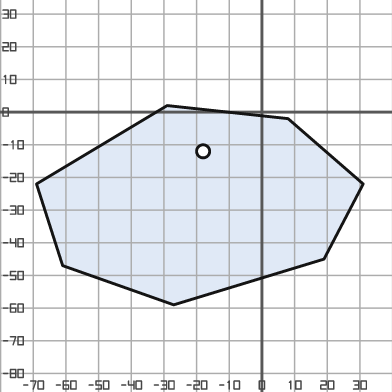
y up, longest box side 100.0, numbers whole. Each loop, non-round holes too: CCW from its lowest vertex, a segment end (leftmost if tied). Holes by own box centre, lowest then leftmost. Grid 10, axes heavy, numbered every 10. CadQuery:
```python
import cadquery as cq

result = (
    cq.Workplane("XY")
    .moveTo(-27.0, -59.0)
    .lineTo(19.0, -45.0)
    .lineTo(31.0, -22.0)
    .lineTo(8.0, -2.0)
    .lineTo(-29.0, 2.0)
    .lineTo(-69.0, -22.0)
    .lineTo(-61.0, -47.0)
    .close()
    .moveTo(-18.0, -12.0)
    .circle(2.0)
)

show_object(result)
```